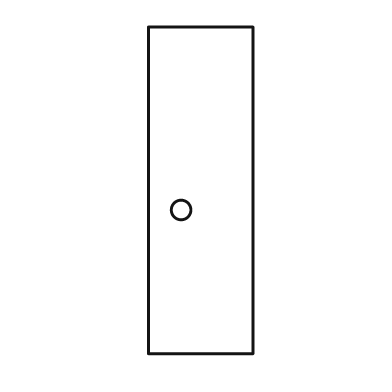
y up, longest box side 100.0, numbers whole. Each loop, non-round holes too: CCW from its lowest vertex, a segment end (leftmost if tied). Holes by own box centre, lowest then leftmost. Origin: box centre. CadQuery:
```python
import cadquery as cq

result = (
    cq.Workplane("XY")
    .moveTo(-16.0, -50.0)
    .lineTo(16.0, -50.0)
    .lineTo(16.0, 50.0)
    .lineTo(-16.0, 50.0)
    .close()
    .moveTo(-6.0, -6.0)
    .circle(3.0)
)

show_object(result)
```